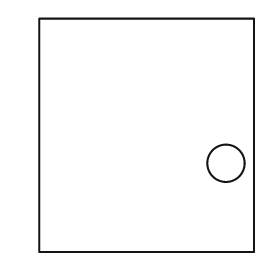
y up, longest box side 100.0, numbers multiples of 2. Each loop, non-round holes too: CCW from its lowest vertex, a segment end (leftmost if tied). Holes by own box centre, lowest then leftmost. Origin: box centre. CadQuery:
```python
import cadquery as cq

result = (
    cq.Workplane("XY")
    .moveTo(-46.0, -50.0)
    .lineTo(46.0, -50.0)
    .lineTo(46.0, 50.0)
    .lineTo(-46.0, 50.0)
    .close()
    .moveTo(34.0, -12.0)
    .circle(8.0)
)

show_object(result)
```